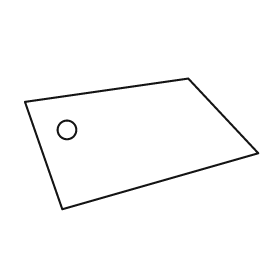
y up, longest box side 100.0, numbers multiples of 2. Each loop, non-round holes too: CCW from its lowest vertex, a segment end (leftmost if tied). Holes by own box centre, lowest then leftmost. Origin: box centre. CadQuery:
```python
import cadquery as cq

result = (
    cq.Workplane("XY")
    .moveTo(-34.0, -28.0)
    .lineTo(50.0, -4.0)
    .lineTo(20.0, 28.0)
    .lineTo(-50.0, 18.0)
    .close()
    .moveTo(-32.0, 6.0)
    .circle(4.0)
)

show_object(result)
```